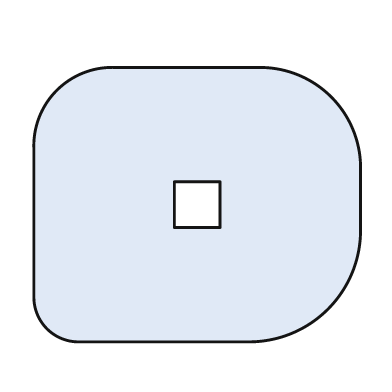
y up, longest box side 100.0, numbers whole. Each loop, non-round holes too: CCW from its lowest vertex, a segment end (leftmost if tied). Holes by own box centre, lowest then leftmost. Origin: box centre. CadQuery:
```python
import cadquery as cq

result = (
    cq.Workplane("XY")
    .moveTo(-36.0, -42.0)
    .lineTo(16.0, -42.0)
    .threePointArc((40.0, -32.0), (50.0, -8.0))
    .lineTo(50.0, 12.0)
    .threePointArc((41.0, 33.0), (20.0, 42.0))
    .lineTo(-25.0, 42.0)
    .threePointArc((-43.0, 35.0), (-50.0, 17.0))
    .lineTo(-50.0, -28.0)
    .threePointArc((-46.0, -38.0), (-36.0, -42.0))
    .close()
    .moveTo(-7.0, -7.0)
    .lineTo(7.0, -7.0)
    .lineTo(7.0, 7.0)
    .lineTo(-7.0, 7.0)
    .close()
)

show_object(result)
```